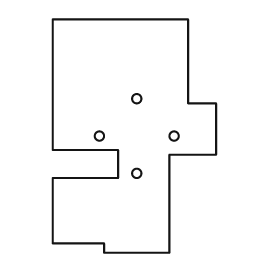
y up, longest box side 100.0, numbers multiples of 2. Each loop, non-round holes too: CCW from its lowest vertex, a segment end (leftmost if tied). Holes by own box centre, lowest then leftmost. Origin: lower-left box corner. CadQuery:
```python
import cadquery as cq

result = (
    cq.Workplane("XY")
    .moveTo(22.0, 0.0)
    .lineTo(50.0, 0.0)
    .lineTo(50.0, 42.0)
    .lineTo(70.0, 42.0)
    .lineTo(70.0, 64.0)
    .lineTo(58.0, 64.0)
    .lineTo(58.0, 100.0)
    .lineTo(0.0, 100.0)
    .lineTo(0.0, 44.0)
    .lineTo(28.0, 44.0)
    .lineTo(28.0, 32.0)
    .lineTo(0.0, 32.0)
    .lineTo(0.0, 4.0)
    .lineTo(22.0, 4.0)
    .close()
    .moveTo(36.0, 34.0)
    .circle(2.0)
    .moveTo(20.0, 50.0)
    .circle(2.0)
    .moveTo(52.0, 50.0)
    .circle(2.0)
    .moveTo(36.0, 66.0)
    .circle(2.0)
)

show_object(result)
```